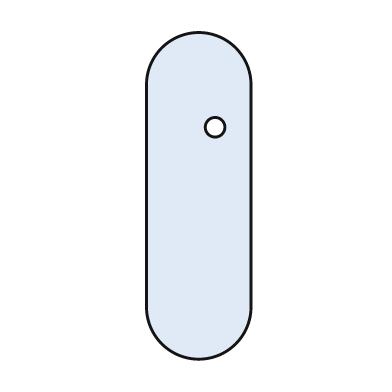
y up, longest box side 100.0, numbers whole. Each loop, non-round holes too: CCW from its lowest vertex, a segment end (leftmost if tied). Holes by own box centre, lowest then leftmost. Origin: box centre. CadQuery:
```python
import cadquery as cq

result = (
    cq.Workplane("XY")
    .moveTo(-16.0, -34.0)
    .threePointArc((0.0, -50.0), (16.0, -34.0))
    .lineTo(16.0, 34.0)
    .threePointArc((0.0, 50.0), (-16.0, 34.0))
    .close()
    .moveTo(5.0, 21.0)
    .circle(3.0)
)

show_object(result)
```